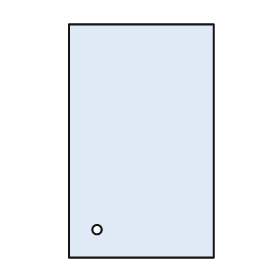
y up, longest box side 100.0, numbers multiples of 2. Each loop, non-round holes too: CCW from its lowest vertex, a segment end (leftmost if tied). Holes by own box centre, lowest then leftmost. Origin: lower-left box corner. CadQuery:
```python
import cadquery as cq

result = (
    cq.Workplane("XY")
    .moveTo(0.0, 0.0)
    .lineTo(62.0, 0.0)
    .lineTo(62.0, 100.0)
    .lineTo(0.0, 100.0)
    .close()
    .moveTo(12.0, 12.0)
    .circle(2.0)
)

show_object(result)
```